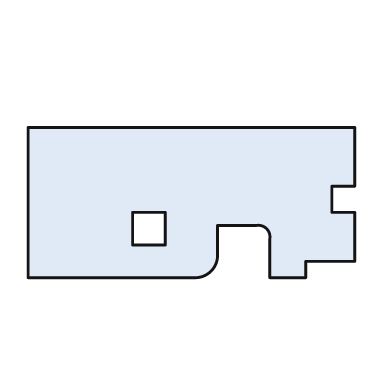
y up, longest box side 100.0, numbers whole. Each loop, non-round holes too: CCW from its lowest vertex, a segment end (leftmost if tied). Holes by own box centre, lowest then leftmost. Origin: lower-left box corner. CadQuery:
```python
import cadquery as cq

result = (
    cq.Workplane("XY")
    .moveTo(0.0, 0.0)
    .lineTo(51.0, 0.0)
    .threePointArc((56.0, 2.0), (58.0, 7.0))
    .lineTo(58.0, 16.0)
    .lineTo(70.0, 16.0)
    .threePointArc((73.0, 15.0), (74.0, 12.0))
    .lineTo(74.0, 0.0)
    .lineTo(85.0, 0.0)
    .lineTo(85.0, 5.0)
    .lineTo(100.0, 5.0)
    .lineTo(100.0, 20.0)
    .lineTo(93.0, 20.0)
    .lineTo(93.0, 28.0)
    .lineTo(100.0, 28.0)
    .lineTo(100.0, 46.0)
    .lineTo(0.0, 46.0)
    .close()
    .moveTo(32.0, 10.0)
    .lineTo(42.0, 10.0)
    .lineTo(42.0, 20.0)
    .lineTo(32.0, 20.0)
    .close()
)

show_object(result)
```